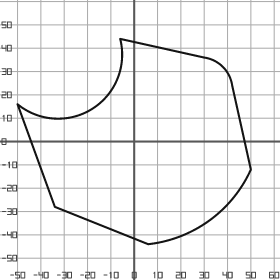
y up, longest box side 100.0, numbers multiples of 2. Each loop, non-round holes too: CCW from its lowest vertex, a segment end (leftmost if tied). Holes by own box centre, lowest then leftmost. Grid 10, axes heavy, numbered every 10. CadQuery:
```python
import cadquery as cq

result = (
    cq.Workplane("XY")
    .moveTo(6.0, -44.0)
    .threePointArc((32.0, -34.0), (50.0, -12.0))
    .lineTo(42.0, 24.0)
    .threePointArc((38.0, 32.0), (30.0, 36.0))
    .lineTo(-6.0, 44.0)
    .threePointArc((-18.0, 14.0), (-50.0, 16.0))
    .lineTo(-34.0, -28.0)
    .close()
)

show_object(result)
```